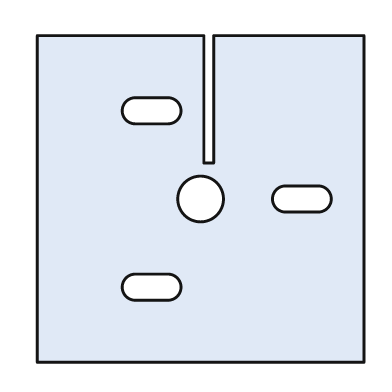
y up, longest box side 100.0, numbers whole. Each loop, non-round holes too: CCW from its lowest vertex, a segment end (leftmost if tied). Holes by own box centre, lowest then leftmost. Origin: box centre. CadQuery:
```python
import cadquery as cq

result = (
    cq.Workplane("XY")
    .moveTo(-50.0, -50.0)
    .lineTo(50.0, -50.0)
    .lineTo(50.0, 50.0)
    .lineTo(4.0, 50.0)
    .lineTo(4.0, 11.0)
    .lineTo(1.0, 11.0)
    .lineTo(1.0, 50.0)
    .lineTo(-50.0, 50.0)
    .close()
    .moveTo(-20.0, -31.0)
    .lineTo(-10.0, -31.0)
    .threePointArc((-6.0, -27.0), (-10.0, -23.0))
    .lineTo(-20.0, -23.0)
    .threePointArc((-24.0, -27.0), (-20.0, -31.0))
    .close()
    .moveTo(0.0, 0.0)
    .circle(7.0)
    .moveTo(26.0, -4.0)
    .lineTo(36.0, -4.0)
    .threePointArc((40.0, 0.0), (36.0, 4.0))
    .lineTo(26.0, 4.0)
    .threePointArc((22.0, 0.0), (26.0, -4.0))
    .close()
    .moveTo(-20.0, 23.0)
    .lineTo(-10.0, 23.0)
    .threePointArc((-6.0, 27.0), (-10.0, 31.0))
    .lineTo(-20.0, 31.0)
    .threePointArc((-24.0, 27.0), (-20.0, 23.0))
    .close()
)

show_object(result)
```